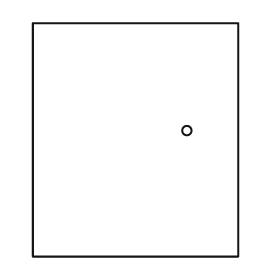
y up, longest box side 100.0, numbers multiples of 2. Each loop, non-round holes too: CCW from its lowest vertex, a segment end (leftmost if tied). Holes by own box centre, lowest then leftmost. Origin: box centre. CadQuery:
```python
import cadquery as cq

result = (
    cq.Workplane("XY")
    .moveTo(-44.0, -50.0)
    .lineTo(44.0, -50.0)
    .lineTo(44.0, 50.0)
    .lineTo(-44.0, 50.0)
    .close()
    .moveTo(22.0, 4.0)
    .circle(2.0)
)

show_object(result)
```